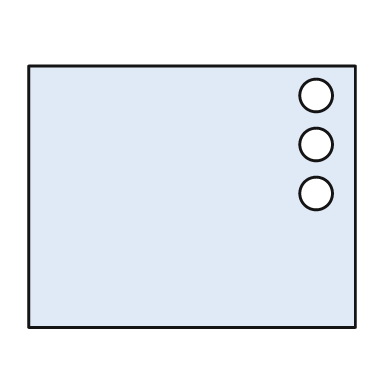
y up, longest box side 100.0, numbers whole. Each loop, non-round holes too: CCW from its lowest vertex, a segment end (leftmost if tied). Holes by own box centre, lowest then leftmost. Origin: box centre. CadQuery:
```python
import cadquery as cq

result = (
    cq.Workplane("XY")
    .moveTo(-50.0, -40.0)
    .lineTo(50.0, -40.0)
    .lineTo(50.0, 40.0)
    .lineTo(-50.0, 40.0)
    .close()
    .moveTo(38.0, 1.0)
    .circle(5.0)
    .moveTo(38.0, 16.0)
    .circle(5.0)
    .moveTo(38.0, 31.0)
    .circle(5.0)
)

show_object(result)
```